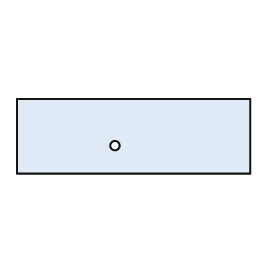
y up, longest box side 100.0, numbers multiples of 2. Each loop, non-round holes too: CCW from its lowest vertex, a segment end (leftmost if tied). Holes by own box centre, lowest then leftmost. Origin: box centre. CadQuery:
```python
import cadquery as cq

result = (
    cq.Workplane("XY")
    .moveTo(-50.0, -16.0)
    .lineTo(50.0, -16.0)
    .lineTo(50.0, 16.0)
    .lineTo(-50.0, 16.0)
    .close()
    .moveTo(-8.0, -4.0)
    .circle(2.0)
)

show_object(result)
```